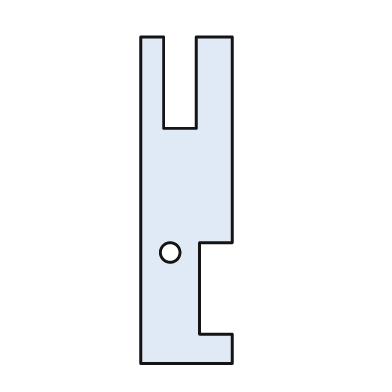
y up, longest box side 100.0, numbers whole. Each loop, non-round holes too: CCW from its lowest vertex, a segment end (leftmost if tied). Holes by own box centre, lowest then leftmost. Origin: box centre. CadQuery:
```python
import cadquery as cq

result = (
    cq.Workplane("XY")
    .moveTo(-14.0, -50.0)
    .lineTo(14.0, -50.0)
    .lineTo(14.0, -41.0)
    .lineTo(4.0, -41.0)
    .lineTo(4.0, -13.0)
    .lineTo(14.0, -13.0)
    .lineTo(14.0, 50.0)
    .lineTo(3.0, 50.0)
    .lineTo(3.0, 22.0)
    .lineTo(-7.0, 22.0)
    .lineTo(-7.0, 50.0)
    .lineTo(-14.0, 50.0)
    .close()
    .moveTo(-5.0, -16.0)
    .circle(3.0)
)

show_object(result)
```